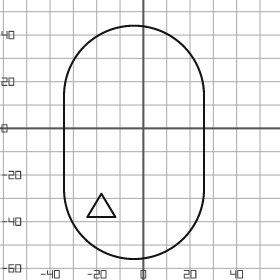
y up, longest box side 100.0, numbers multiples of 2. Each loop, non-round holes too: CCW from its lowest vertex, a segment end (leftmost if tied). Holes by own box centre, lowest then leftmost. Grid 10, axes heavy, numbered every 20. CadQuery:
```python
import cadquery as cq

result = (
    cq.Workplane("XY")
    .moveTo(-34.0, -26.0)
    .threePointArc((-4.0, -56.0), (26.0, -26.0))
    .lineTo(26.0, 14.0)
    .threePointArc((-4.0, 44.0), (-34.0, 14.0))
    .close()
    .moveTo(-24.0, -38.0)
    .lineTo(-12.0, -38.0)
    .lineTo(-18.0, -28.0)
    .close()
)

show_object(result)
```